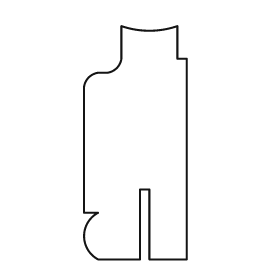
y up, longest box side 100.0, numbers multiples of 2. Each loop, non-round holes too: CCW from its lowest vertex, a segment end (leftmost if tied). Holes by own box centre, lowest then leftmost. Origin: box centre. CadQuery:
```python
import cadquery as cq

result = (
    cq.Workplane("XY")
    .moveTo(-16.0, -50.0)
    .lineTo(2.0, -50.0)
    .lineTo(2.0, -20.0)
    .lineTo(6.0, -20.0)
    .lineTo(6.0, -50.0)
    .lineTo(22.0, -50.0)
    .lineTo(22.0, 36.0)
    .lineTo(18.0, 36.0)
    .lineTo(18.0, 50.0)
    .threePointArc((6.0, 48.0), (-6.0, 50.0))
    .lineTo(-6.0, 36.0)
    .threePointArc((-8.0, 32.0), (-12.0, 30.0))
    .lineTo(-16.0, 30.0)
    .threePointArc((-20.0, 28.0), (-22.0, 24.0))
    .lineTo(-22.0, -30.0)
    .lineTo(-16.0, -30.0)
    .threePointArc((-22.0, -40.0), (-16.0, -50.0))
    .close()
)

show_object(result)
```